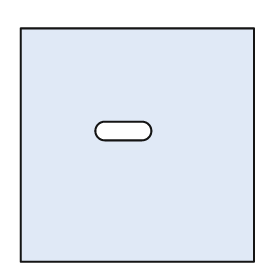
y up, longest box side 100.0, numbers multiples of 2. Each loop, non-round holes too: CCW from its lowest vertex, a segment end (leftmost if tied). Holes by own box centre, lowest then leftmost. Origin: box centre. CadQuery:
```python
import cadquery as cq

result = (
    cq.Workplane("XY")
    .moveTo(-50.0, -50.0)
    .lineTo(50.0, -50.0)
    .lineTo(50.0, 50.0)
    .lineTo(-50.0, 50.0)
    .close()
    .moveTo(-14.0, 2.0)
    .lineTo(2.0, 2.0)
    .threePointArc((6.0, 6.0), (2.0, 10.0))
    .lineTo(-14.0, 10.0)
    .threePointArc((-18.0, 6.0), (-14.0, 2.0))
    .close()
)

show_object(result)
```